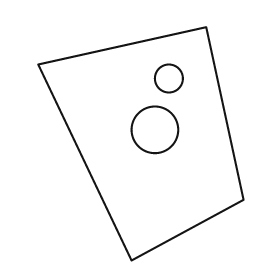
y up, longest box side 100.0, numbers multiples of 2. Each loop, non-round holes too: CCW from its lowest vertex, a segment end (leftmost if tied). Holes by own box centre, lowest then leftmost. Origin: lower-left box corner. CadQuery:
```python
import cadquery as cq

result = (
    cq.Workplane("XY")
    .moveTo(40.0, 0.0)
    .lineTo(88.0, 26.0)
    .lineTo(72.0, 100.0)
    .lineTo(0.0, 84.0)
    .close()
    .moveTo(50.0, 56.0)
    .circle(10.0)
    .moveTo(56.0, 78.0)
    .circle(6.0)
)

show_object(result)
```